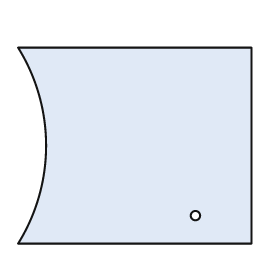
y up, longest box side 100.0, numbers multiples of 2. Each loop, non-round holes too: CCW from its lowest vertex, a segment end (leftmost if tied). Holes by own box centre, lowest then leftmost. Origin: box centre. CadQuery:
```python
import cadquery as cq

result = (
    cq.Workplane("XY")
    .moveTo(-50.0, -42.0)
    .lineTo(50.0, -42.0)
    .lineTo(50.0, 42.0)
    .lineTo(-50.0, 42.0)
    .threePointArc((-38.0, 0.0), (-50.0, -42.0))
    .close()
    .moveTo(26.0, -30.0)
    .circle(2.0)
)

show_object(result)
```